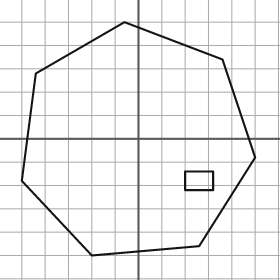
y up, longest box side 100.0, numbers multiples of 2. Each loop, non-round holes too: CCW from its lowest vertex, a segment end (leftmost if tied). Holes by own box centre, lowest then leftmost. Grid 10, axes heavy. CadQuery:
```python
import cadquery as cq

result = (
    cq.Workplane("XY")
    .moveTo(-20.0, -50.0)
    .lineTo(26.0, -46.0)
    .lineTo(50.0, -8.0)
    .lineTo(36.0, 34.0)
    .lineTo(-6.0, 50.0)
    .lineTo(-44.0, 28.0)
    .lineTo(-50.0, -18.0)
    .close()
    .moveTo(20.0, -22.0)
    .lineTo(32.0, -22.0)
    .lineTo(32.0, -14.0)
    .lineTo(20.0, -14.0)
    .close()
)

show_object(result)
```